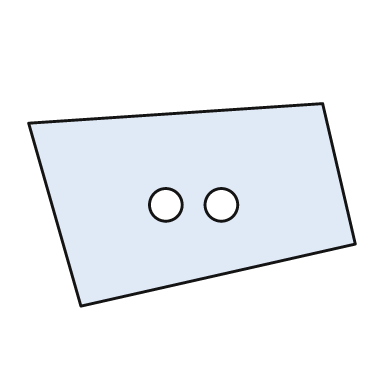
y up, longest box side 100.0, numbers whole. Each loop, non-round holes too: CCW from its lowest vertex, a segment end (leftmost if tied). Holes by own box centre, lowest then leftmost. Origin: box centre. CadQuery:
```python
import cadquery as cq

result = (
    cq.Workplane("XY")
    .moveTo(-34.0, -31.0)
    .lineTo(50.0, -12.0)
    .lineTo(40.0, 31.0)
    .lineTo(-50.0, 25.0)
    .close()
    .moveTo(-8.0, 0.0)
    .circle(5.0)
    .moveTo(9.0, 0.0)
    .circle(5.0)
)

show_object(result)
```